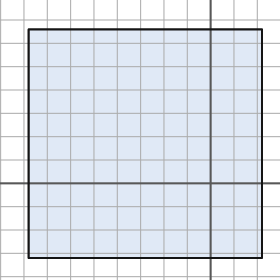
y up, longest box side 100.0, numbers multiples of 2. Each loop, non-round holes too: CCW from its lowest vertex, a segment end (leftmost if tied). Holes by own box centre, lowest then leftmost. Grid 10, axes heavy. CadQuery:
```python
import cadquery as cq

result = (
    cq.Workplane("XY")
    .moveTo(-78.0, -32.0)
    .lineTo(22.0, -32.0)
    .lineTo(22.0, 66.0)
    .lineTo(-78.0, 66.0)
    .close()
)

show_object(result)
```